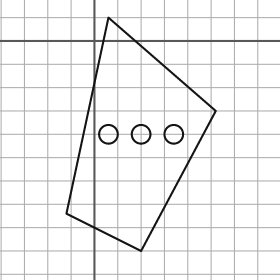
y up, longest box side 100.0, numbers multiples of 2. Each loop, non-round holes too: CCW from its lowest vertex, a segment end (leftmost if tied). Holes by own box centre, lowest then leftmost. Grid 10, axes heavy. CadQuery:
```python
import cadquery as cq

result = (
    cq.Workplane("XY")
    .moveTo(20.0, -90.0)
    .lineTo(52.0, -30.0)
    .lineTo(6.0, 10.0)
    .lineTo(-12.0, -74.0)
    .close()
    .moveTo(6.0, -40.0)
    .circle(4.0)
    .moveTo(20.0, -40.0)
    .circle(4.0)
    .moveTo(34.0, -40.0)
    .circle(4.0)
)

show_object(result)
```